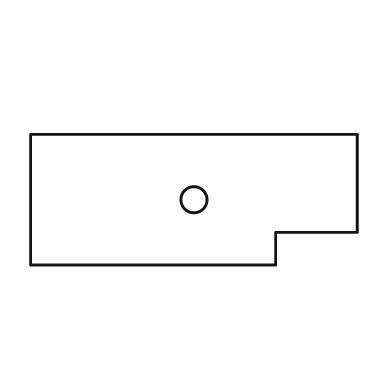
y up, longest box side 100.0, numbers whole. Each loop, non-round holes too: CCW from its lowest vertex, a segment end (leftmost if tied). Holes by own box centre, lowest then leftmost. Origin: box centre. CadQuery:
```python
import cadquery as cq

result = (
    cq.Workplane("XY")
    .moveTo(-50.0, -20.0)
    .lineTo(25.0, -20.0)
    .lineTo(25.0, -10.0)
    .lineTo(50.0, -10.0)
    .lineTo(50.0, 20.0)
    .lineTo(-50.0, 20.0)
    .close()
    .moveTo(0.0, 0.0)
    .circle(4.0)
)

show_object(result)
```